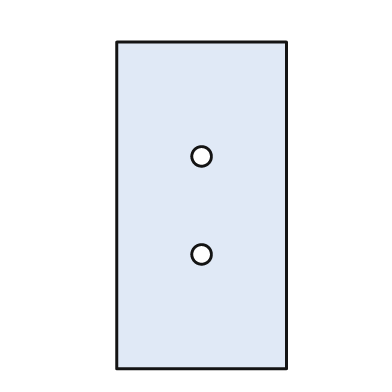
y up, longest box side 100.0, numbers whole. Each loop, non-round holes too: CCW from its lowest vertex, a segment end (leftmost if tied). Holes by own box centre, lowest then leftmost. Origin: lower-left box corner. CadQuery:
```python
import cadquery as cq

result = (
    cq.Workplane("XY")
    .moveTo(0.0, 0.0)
    .lineTo(52.0, 0.0)
    .lineTo(52.0, 100.0)
    .lineTo(0.0, 100.0)
    .close()
    .moveTo(26.0, 35.0)
    .circle(3.0)
    .moveTo(26.0, 65.0)
    .circle(3.0)
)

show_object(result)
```